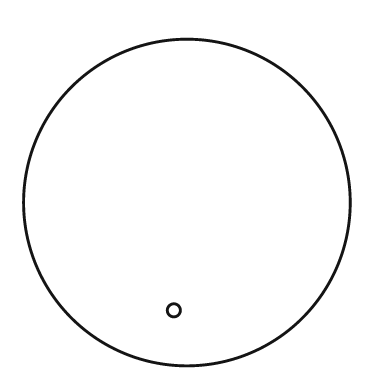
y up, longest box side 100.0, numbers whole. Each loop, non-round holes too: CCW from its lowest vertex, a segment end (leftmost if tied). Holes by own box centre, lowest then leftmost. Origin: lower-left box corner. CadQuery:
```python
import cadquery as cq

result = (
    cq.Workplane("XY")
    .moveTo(50.0, 50.0)
    .circle(50.0)
    .moveTo(46.0, 17.0)
    .circle(2.0)
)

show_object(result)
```